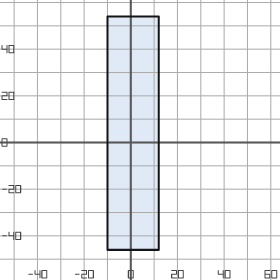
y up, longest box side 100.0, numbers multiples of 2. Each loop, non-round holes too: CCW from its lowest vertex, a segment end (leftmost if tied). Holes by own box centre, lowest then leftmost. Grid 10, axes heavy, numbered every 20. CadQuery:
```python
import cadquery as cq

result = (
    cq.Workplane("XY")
    .moveTo(-10.0, -46.0)
    .lineTo(12.0, -46.0)
    .lineTo(12.0, 54.0)
    .lineTo(-10.0, 54.0)
    .close()
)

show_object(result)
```